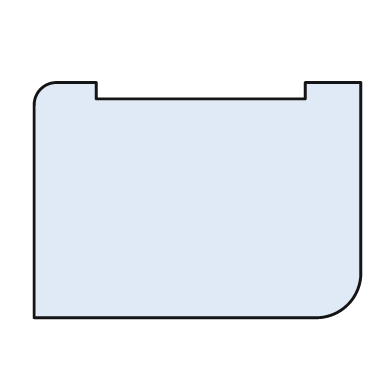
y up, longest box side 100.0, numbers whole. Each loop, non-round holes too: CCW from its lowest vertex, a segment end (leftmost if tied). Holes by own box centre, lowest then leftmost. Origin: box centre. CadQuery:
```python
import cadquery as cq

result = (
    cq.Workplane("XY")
    .moveTo(-50.0, -36.0)
    .lineTo(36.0, -36.0)
    .threePointArc((46.0, -32.0), (50.0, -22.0))
    .lineTo(50.0, 36.0)
    .lineTo(33.0, 36.0)
    .lineTo(33.0, 31.0)
    .lineTo(-31.0, 31.0)
    .lineTo(-31.0, 36.0)
    .lineTo(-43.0, 36.0)
    .threePointArc((-48.0, 34.0), (-50.0, 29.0))
    .close()
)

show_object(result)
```